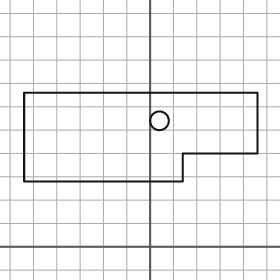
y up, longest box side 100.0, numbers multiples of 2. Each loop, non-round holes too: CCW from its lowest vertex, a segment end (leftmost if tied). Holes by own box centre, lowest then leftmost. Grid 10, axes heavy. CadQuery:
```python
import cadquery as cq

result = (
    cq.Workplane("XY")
    .moveTo(-54.0, 28.0)
    .lineTo(14.0, 28.0)
    .lineTo(14.0, 40.0)
    .lineTo(46.0, 40.0)
    .lineTo(46.0, 66.0)
    .lineTo(-54.0, 66.0)
    .close()
    .moveTo(4.0, 54.0)
    .circle(4.0)
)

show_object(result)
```